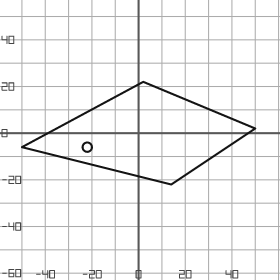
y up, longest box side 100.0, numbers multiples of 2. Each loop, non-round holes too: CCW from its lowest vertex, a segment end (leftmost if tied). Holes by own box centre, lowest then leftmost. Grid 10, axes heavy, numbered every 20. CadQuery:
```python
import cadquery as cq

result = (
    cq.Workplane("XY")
    .moveTo(14.0, -22.0)
    .lineTo(50.0, 2.0)
    .lineTo(2.0, 22.0)
    .lineTo(-50.0, -6.0)
    .close()
    .moveTo(-22.0, -6.0)
    .circle(2.0)
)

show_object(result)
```